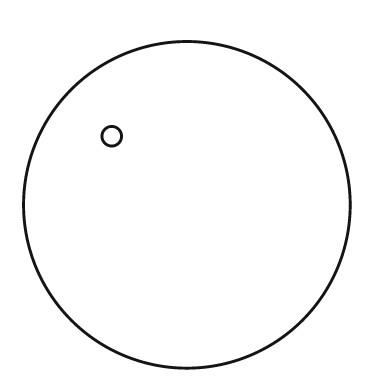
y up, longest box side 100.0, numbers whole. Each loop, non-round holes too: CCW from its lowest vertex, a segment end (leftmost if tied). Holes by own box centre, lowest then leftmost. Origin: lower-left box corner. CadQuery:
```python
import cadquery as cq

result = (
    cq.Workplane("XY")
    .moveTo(50.0, 50.0)
    .circle(50.0)
    .moveTo(27.0, 71.0)
    .circle(3.0)
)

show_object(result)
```